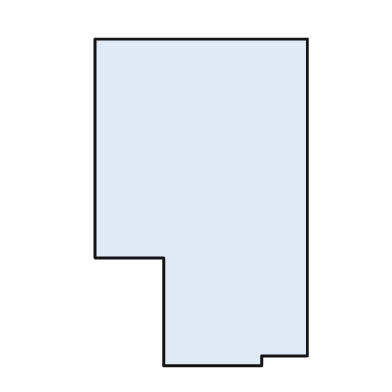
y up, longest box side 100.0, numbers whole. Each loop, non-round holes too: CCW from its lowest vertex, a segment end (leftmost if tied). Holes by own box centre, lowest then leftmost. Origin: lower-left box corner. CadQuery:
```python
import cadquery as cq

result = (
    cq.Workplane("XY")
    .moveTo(21.0, 0.0)
    .lineTo(51.0, 0.0)
    .lineTo(51.0, 3.0)
    .lineTo(65.0, 3.0)
    .lineTo(65.0, 100.0)
    .lineTo(0.0, 100.0)
    .lineTo(0.0, 33.0)
    .lineTo(21.0, 33.0)
    .close()
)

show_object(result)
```